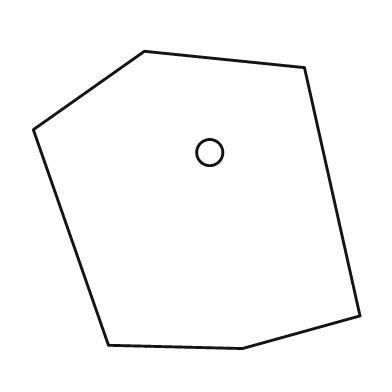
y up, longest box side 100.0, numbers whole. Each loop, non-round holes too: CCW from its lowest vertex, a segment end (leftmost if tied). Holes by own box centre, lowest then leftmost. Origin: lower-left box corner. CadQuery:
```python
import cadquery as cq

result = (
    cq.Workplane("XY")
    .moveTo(64.0, 0.0)
    .lineTo(100.0, 10.0)
    .lineTo(83.0, 86.0)
    .lineTo(34.0, 91.0)
    .lineTo(0.0, 67.0)
    .lineTo(23.0, 1.0)
    .close()
    .moveTo(54.0, 60.0)
    .circle(4.0)
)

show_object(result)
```